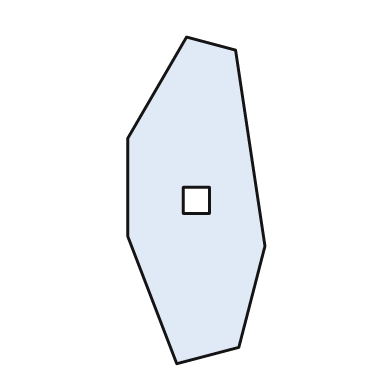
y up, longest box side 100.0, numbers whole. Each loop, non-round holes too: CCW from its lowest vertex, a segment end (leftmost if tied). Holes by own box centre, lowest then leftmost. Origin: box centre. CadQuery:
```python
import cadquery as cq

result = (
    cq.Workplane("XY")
    .moveTo(-6.0, -50.0)
    .lineTo(13.0, -45.0)
    .lineTo(21.0, -14.0)
    .lineTo(12.0, 46.0)
    .lineTo(-3.0, 50.0)
    .lineTo(-21.0, 19.0)
    .lineTo(-21.0, -11.0)
    .close()
    .moveTo(-4.0, -4.0)
    .lineTo(4.0, -4.0)
    .lineTo(4.0, 4.0)
    .lineTo(-4.0, 4.0)
    .close()
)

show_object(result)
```